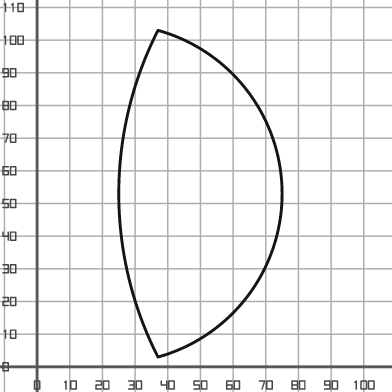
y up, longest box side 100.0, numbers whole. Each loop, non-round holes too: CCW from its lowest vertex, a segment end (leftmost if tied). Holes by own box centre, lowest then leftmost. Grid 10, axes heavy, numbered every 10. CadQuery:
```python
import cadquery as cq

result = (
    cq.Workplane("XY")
    .moveTo(37.0, 3.0)
    .threePointArc((75.0, 53.0), (37.0, 103.0))
    .threePointArc((25.0, 53.0), (37.0, 3.0))
    .close()
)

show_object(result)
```